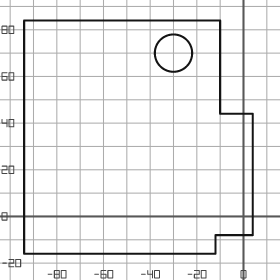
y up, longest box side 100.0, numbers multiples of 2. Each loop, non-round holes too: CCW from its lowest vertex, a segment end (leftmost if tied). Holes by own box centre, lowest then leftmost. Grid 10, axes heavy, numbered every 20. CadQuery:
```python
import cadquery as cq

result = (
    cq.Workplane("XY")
    .moveTo(-94.0, -16.0)
    .lineTo(-12.0, -16.0)
    .lineTo(-12.0, -8.0)
    .lineTo(4.0, -8.0)
    .lineTo(4.0, 44.0)
    .lineTo(-10.0, 44.0)
    .lineTo(-10.0, 84.0)
    .lineTo(-94.0, 84.0)
    .close()
    .moveTo(-30.0, 70.0)
    .circle(8.0)
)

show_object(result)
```